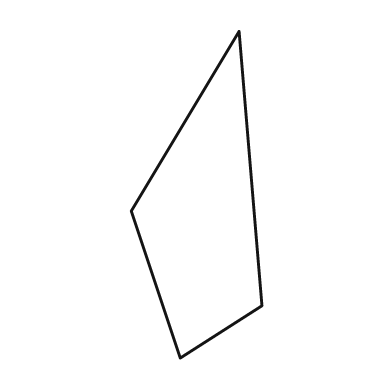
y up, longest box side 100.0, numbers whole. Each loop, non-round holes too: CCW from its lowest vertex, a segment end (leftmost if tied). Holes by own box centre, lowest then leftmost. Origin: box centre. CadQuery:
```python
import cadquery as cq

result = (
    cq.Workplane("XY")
    .moveTo(-5.0, -50.0)
    .lineTo(20.0, -34.0)
    .lineTo(13.0, 50.0)
    .lineTo(-20.0, -5.0)
    .close()
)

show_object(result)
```